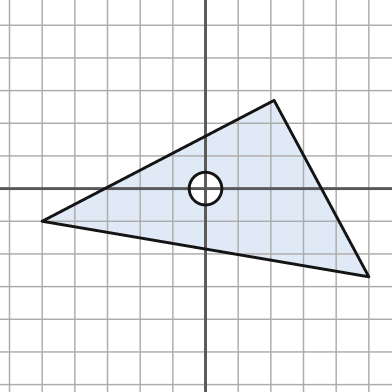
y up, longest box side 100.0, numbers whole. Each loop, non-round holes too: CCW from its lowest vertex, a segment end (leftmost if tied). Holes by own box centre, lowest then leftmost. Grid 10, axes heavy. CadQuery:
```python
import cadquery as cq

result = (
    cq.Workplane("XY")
    .moveTo(50.0, -27.0)
    .lineTo(21.0, 27.0)
    .lineTo(-50.0, -10.0)
    .close()
    .moveTo(0.0, 0.0)
    .circle(5.0)
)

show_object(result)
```